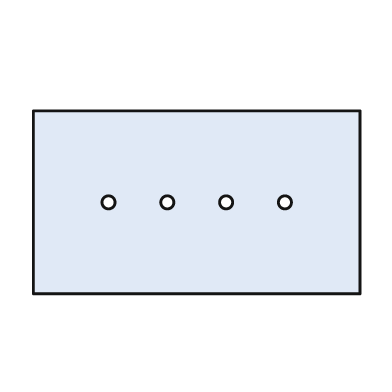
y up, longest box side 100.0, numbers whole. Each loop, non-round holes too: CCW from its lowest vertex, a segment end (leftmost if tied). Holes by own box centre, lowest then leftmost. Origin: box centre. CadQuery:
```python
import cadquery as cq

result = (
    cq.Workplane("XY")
    .moveTo(-50.0, -28.0)
    .lineTo(50.0, -28.0)
    .lineTo(50.0, 28.0)
    .lineTo(-50.0, 28.0)
    .close()
    .moveTo(-27.0, 0.0)
    .circle(2.0)
    .moveTo(-9.0, 0.0)
    .circle(2.0)
    .moveTo(9.0, 0.0)
    .circle(2.0)
    .moveTo(27.0, 0.0)
    .circle(2.0)
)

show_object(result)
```